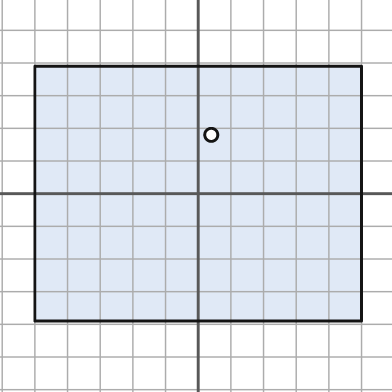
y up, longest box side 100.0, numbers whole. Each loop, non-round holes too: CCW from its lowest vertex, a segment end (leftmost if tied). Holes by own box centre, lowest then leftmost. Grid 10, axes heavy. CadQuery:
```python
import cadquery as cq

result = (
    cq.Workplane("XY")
    .moveTo(-50.0, -39.0)
    .lineTo(50.0, -39.0)
    .lineTo(50.0, 39.0)
    .lineTo(-50.0, 39.0)
    .close()
    .moveTo(4.0, 18.0)
    .circle(2.0)
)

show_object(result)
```